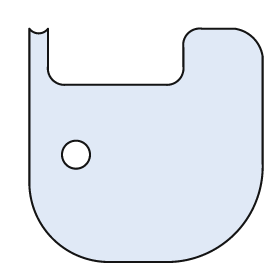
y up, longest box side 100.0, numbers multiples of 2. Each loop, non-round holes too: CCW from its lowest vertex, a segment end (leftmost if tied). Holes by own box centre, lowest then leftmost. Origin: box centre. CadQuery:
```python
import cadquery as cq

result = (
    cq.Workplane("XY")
    .moveTo(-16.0, -50.0)
    .lineTo(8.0, -50.0)
    .threePointArc((38.0, -38.0), (50.0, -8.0))
    .lineTo(50.0, 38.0)
    .threePointArc((46.0, 46.0), (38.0, 50.0))
    .lineTo(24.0, 50.0)
    .threePointArc((18.0, 48.0), (16.0, 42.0))
    .lineTo(16.0, 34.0)
    .threePointArc((14.0, 28.0), (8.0, 26.0))
    .lineTo(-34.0, 26.0)
    .threePointArc((-40.0, 28.0), (-42.0, 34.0))
    .lineTo(-42.0, 50.0)
    .threePointArc((-46.0, 48.0), (-50.0, 50.0))
    .lineTo(-50.0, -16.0)
    .threePointArc((-40.0, -40.0), (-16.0, -50.0))
    .close()
    .moveTo(-30.0, -4.0)
    .circle(6.0)
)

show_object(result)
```